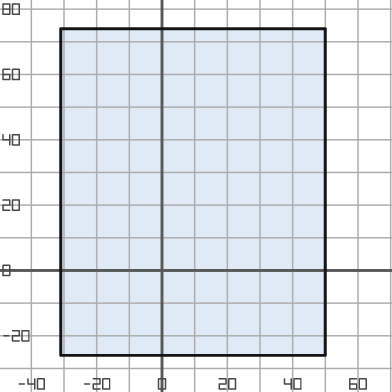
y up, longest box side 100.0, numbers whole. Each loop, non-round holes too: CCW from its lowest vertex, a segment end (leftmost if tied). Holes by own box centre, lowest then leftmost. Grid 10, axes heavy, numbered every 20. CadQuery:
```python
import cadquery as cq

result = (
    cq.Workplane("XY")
    .moveTo(-31.0, -26.0)
    .lineTo(50.0, -26.0)
    .lineTo(50.0, 74.0)
    .lineTo(-31.0, 74.0)
    .close()
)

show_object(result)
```